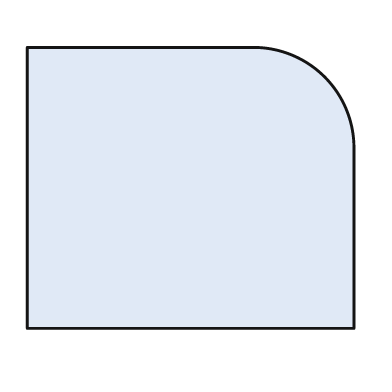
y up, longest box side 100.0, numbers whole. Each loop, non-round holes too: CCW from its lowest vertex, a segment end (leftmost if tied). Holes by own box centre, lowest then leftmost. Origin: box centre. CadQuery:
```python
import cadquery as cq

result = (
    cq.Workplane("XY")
    .moveTo(-50.0, -43.0)
    .lineTo(50.0, -43.0)
    .lineTo(50.0, 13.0)
    .threePointArc((41.0, 34.0), (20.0, 43.0))
    .lineTo(-50.0, 43.0)
    .close()
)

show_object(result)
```